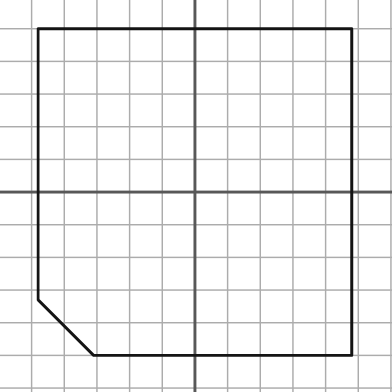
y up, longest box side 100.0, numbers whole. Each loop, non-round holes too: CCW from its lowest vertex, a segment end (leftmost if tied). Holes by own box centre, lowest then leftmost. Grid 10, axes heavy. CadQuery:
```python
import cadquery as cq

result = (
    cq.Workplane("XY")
    .moveTo(-31.0, -50.0)
    .lineTo(48.0, -50.0)
    .lineTo(48.0, 50.0)
    .lineTo(-48.0, 50.0)
    .lineTo(-48.0, -33.0)
    .close()
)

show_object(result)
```